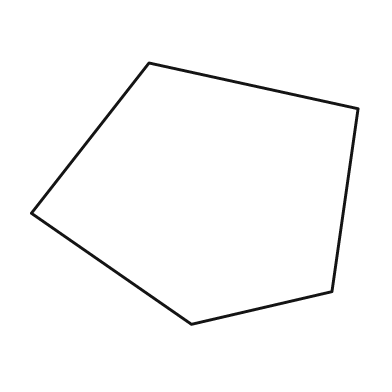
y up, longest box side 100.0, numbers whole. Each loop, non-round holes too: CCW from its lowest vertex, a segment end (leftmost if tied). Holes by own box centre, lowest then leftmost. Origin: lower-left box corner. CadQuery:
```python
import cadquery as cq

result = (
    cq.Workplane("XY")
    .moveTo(49.0, 0.0)
    .lineTo(92.0, 10.0)
    .lineTo(100.0, 66.0)
    .lineTo(36.0, 80.0)
    .lineTo(0.0, 34.0)
    .close()
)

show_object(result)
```